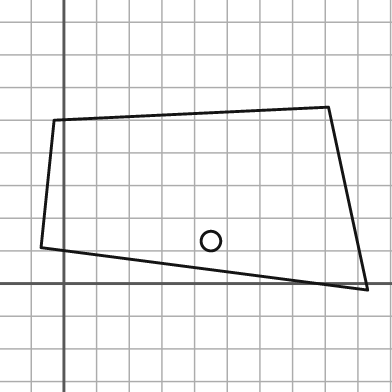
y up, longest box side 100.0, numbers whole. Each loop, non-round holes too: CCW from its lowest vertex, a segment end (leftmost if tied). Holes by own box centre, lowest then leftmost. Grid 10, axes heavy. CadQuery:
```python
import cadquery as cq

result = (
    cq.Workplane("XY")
    .moveTo(93.0, -2.0)
    .lineTo(81.0, 54.0)
    .lineTo(-3.0, 50.0)
    .lineTo(-7.0, 11.0)
    .close()
    .moveTo(45.0, 13.0)
    .circle(3.0)
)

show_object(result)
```